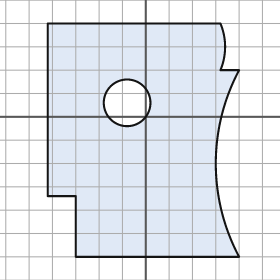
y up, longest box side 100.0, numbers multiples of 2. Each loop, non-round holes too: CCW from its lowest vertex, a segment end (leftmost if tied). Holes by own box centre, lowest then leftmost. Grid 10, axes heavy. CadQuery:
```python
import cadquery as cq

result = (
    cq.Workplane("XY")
    .moveTo(-30.0, -60.0)
    .lineTo(40.0, -60.0)
    .threePointArc((30.0, -20.0), (40.0, 20.0))
    .lineTo(32.0, 20.0)
    .threePointArc((34.0, 30.0), (32.0, 40.0))
    .lineTo(-42.0, 40.0)
    .lineTo(-42.0, -34.0)
    .lineTo(-30.0, -34.0)
    .close()
    .moveTo(-8.0, 6.0)
    .circle(10.0)
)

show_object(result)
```